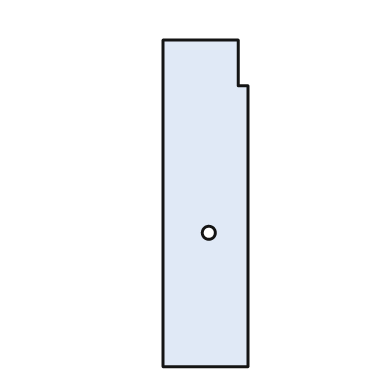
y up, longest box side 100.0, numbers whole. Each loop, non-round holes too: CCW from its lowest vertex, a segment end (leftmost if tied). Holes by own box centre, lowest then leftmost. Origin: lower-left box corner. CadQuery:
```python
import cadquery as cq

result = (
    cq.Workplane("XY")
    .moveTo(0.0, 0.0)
    .lineTo(26.0, 0.0)
    .lineTo(26.0, 86.0)
    .lineTo(23.0, 86.0)
    .lineTo(23.0, 100.0)
    .lineTo(0.0, 100.0)
    .close()
    .moveTo(14.0, 41.0)
    .circle(2.0)
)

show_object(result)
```